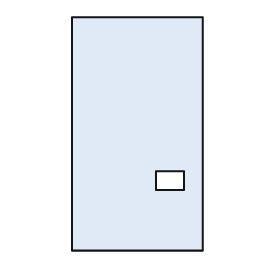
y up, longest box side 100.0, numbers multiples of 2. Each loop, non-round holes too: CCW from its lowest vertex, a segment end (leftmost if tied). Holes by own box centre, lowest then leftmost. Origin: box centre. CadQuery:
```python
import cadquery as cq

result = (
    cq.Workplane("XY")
    .moveTo(-28.0, -50.0)
    .lineTo(28.0, -50.0)
    .lineTo(28.0, 50.0)
    .lineTo(-28.0, 50.0)
    .close()
    .moveTo(8.0, -24.0)
    .lineTo(20.0, -24.0)
    .lineTo(20.0, -16.0)
    .lineTo(8.0, -16.0)
    .close()
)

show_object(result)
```